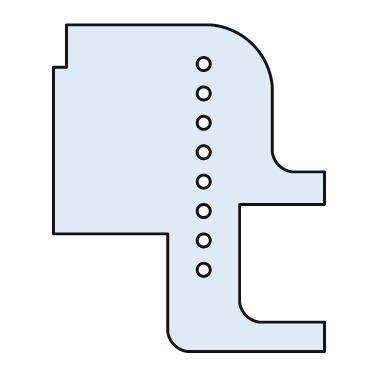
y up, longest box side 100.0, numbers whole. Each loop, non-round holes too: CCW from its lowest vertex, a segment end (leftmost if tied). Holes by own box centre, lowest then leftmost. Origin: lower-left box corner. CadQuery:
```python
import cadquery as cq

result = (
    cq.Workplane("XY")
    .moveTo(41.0, 0.0)
    .lineTo(83.0, 0.0)
    .lineTo(83.0, 9.0)
    .lineTo(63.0, 9.0)
    .threePointArc((59.0, 11.0), (57.0, 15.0))
    .lineTo(57.0, 45.0)
    .lineTo(83.0, 45.0)
    .lineTo(83.0, 55.0)
    .lineTo(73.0, 55.0)
    .threePointArc((69.0, 57.0), (67.0, 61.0))
    .lineTo(67.0, 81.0)
    .threePointArc((61.0, 94.0), (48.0, 100.0))
    .lineTo(4.0, 100.0)
    .lineTo(4.0, 87.0)
    .lineTo(0.0, 87.0)
    .lineTo(0.0, 36.0)
    .lineTo(35.0, 36.0)
    .lineTo(35.0, 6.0)
    .threePointArc((37.0, 2.0), (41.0, 0.0))
    .close()
    .moveTo(46.0, 25.0)
    .circle(2.0)
    .moveTo(46.0, 34.0)
    .circle(2.0)
    .moveTo(46.0, 43.0)
    .circle(2.0)
    .moveTo(46.0, 52.0)
    .circle(2.0)
    .moveTo(46.0, 61.0)
    .circle(2.0)
    .moveTo(46.0, 70.0)
    .circle(2.0)
    .moveTo(46.0, 79.0)
    .circle(2.0)
    .moveTo(46.0, 88.0)
    .circle(2.0)
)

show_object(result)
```